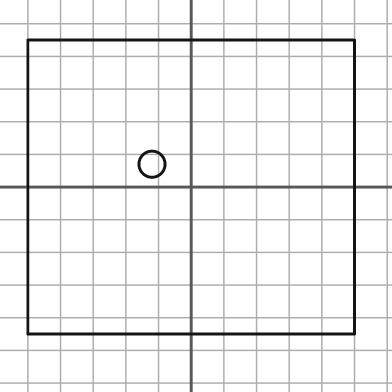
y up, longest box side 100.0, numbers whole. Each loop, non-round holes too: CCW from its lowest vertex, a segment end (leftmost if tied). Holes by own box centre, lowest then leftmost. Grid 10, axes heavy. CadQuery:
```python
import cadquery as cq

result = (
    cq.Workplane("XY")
    .moveTo(-50.0, -45.0)
    .lineTo(50.0, -45.0)
    .lineTo(50.0, 45.0)
    .lineTo(-50.0, 45.0)
    .close()
    .moveTo(-12.0, 7.0)
    .circle(4.0)
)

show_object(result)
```